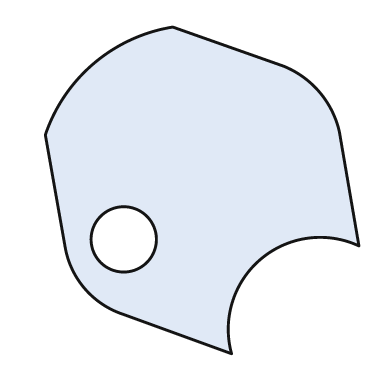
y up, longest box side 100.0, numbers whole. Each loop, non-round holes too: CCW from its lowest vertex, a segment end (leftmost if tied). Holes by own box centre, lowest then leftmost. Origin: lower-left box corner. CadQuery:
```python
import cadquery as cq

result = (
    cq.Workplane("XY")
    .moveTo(57.0, 0.0)
    .threePointArc((66.0, 29.0), (96.0, 33.0))
    .lineTo(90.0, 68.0)
    .threePointArc((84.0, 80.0), (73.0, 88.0))
    .lineTo(39.0, 100.0)
    .threePointArc((15.0, 89.0), (0.0, 67.0))
    .lineTo(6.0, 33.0)
    .threePointArc((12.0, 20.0), (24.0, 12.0))
    .close()
    .moveTo(24.0, 35.0)
    .circle(10.0)
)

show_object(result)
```